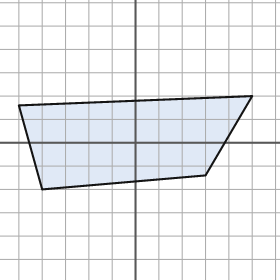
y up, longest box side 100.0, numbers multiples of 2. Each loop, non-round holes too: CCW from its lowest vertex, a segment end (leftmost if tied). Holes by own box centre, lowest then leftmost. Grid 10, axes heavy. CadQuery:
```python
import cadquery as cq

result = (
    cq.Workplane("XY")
    .moveTo(-40.0, -20.0)
    .lineTo(30.0, -14.0)
    .lineTo(50.0, 20.0)
    .lineTo(-50.0, 16.0)
    .close()
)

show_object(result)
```